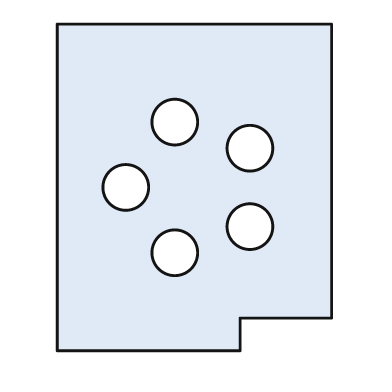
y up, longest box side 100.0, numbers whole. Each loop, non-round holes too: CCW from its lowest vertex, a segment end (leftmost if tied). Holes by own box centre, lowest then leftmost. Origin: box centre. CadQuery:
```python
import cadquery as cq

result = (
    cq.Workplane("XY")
    .moveTo(-42.0, -50.0)
    .lineTo(14.0, -50.0)
    .lineTo(14.0, -40.0)
    .lineTo(42.0, -40.0)
    .lineTo(42.0, 50.0)
    .lineTo(-42.0, 50.0)
    .close()
    .moveTo(-6.0, -20.0)
    .circle(7.0)
    .moveTo(17.0, -12.0)
    .circle(7.0)
    .moveTo(-21.0, 0.0)
    .circle(7.0)
    .moveTo(17.0, 12.0)
    .circle(7.0)
    .moveTo(-6.0, 20.0)
    .circle(7.0)
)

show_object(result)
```